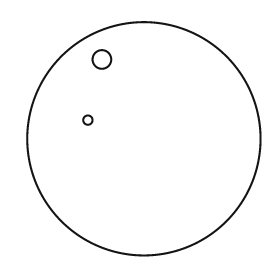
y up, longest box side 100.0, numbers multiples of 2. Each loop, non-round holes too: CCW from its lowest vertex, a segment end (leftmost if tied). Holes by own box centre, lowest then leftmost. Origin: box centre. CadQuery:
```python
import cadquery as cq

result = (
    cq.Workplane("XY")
    .moveTo(0.0, 0.0)
    .circle(50.0)
    .moveTo(-24.0, 8.0)
    .circle(2.0)
    .moveTo(-18.0, 34.0)
    .circle(4.0)
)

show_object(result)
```